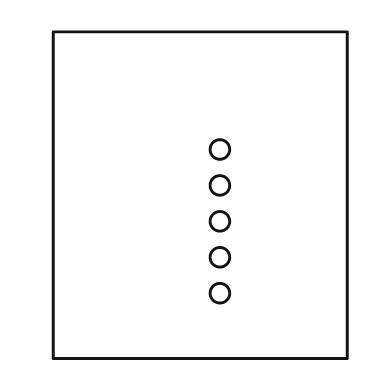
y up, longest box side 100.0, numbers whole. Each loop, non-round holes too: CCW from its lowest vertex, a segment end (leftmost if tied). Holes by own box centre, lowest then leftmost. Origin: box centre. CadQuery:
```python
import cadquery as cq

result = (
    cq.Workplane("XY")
    .moveTo(-45.0, -50.0)
    .lineTo(45.0, -50.0)
    .lineTo(45.0, 50.0)
    .lineTo(-45.0, 50.0)
    .close()
    .moveTo(6.0, -30.0)
    .circle(3.0)
    .moveTo(6.0, -19.0)
    .circle(3.0)
    .moveTo(6.0, -8.0)
    .circle(3.0)
    .moveTo(6.0, 3.0)
    .circle(3.0)
    .moveTo(6.0, 14.0)
    .circle(3.0)
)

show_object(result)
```